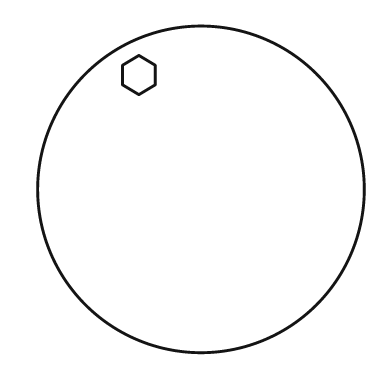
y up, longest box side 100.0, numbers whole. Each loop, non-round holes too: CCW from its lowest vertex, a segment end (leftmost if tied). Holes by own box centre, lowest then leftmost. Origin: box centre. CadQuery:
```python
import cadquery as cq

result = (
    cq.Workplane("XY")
    .moveTo(0.0, 0.0)
    .circle(50.0)
    .moveTo(-19.0, 29.0)
    .lineTo(-14.0, 32.0)
    .lineTo(-14.0, 38.0)
    .lineTo(-19.0, 41.0)
    .lineTo(-24.0, 38.0)
    .lineTo(-24.0, 32.0)
    .close()
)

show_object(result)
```